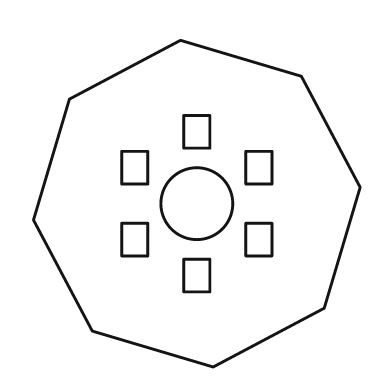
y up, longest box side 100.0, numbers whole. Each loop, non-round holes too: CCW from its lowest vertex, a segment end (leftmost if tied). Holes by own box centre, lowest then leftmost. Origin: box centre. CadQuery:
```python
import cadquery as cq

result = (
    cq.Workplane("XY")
    .moveTo(5.0, -50.0)
    .lineTo(39.0, -32.0)
    .lineTo(50.0, 5.0)
    .lineTo(32.0, 39.0)
    .lineTo(-5.0, 50.0)
    .lineTo(-39.0, 32.0)
    .lineTo(-50.0, -5.0)
    .lineTo(-32.0, -39.0)
    .close()
    .moveTo(-4.0, -27.0)
    .lineTo(4.0, -27.0)
    .lineTo(4.0, -17.0)
    .lineTo(-4.0, -17.0)
    .close()
    .moveTo(-23.0, -16.0)
    .lineTo(-15.0, -16.0)
    .lineTo(-15.0, -6.0)
    .lineTo(-23.0, -6.0)
    .close()
    .moveTo(15.0, -16.0)
    .lineTo(23.0, -16.0)
    .lineTo(23.0, -6.0)
    .lineTo(15.0, -6.0)
    .close()
    .moveTo(0.0, 0.0)
    .circle(11.0)
    .moveTo(-23.0, 6.0)
    .lineTo(-15.0, 6.0)
    .lineTo(-15.0, 16.0)
    .lineTo(-23.0, 16.0)
    .close()
    .moveTo(15.0, 6.0)
    .lineTo(23.0, 6.0)
    .lineTo(23.0, 16.0)
    .lineTo(15.0, 16.0)
    .close()
    .moveTo(-4.0, 17.0)
    .lineTo(4.0, 17.0)
    .lineTo(4.0, 27.0)
    .lineTo(-4.0, 27.0)
    .close()
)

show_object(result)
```